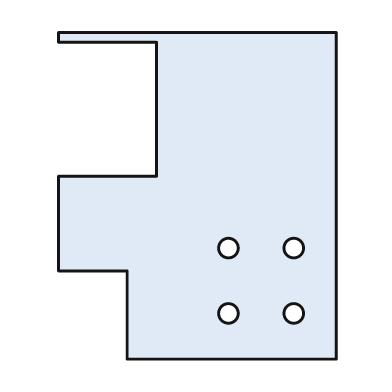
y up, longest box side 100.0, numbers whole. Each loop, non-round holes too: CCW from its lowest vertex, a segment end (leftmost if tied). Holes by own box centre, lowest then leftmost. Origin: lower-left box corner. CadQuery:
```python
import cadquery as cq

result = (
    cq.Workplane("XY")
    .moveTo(21.0, 0.0)
    .lineTo(85.0, 0.0)
    .lineTo(85.0, 100.0)
    .lineTo(0.0, 100.0)
    .lineTo(0.0, 97.0)
    .lineTo(30.0, 97.0)
    .lineTo(30.0, 56.0)
    .lineTo(0.0, 56.0)
    .lineTo(0.0, 27.0)
    .lineTo(21.0, 27.0)
    .close()
    .moveTo(52.0, 14.0)
    .circle(3.0)
    .moveTo(72.0, 14.0)
    .circle(3.0)
    .moveTo(52.0, 34.0)
    .circle(3.0)
    .moveTo(72.0, 34.0)
    .circle(3.0)
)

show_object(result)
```